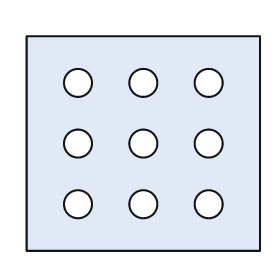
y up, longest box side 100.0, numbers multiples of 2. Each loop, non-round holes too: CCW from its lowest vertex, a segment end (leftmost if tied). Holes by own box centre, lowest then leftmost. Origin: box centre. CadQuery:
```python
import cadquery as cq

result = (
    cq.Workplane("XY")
    .moveTo(-50.0, -46.0)
    .lineTo(50.0, -46.0)
    .lineTo(50.0, 46.0)
    .lineTo(-50.0, 46.0)
    .close()
    .moveTo(-28.0, -26.0)
    .circle(6.0)
    .moveTo(0.0, -26.0)
    .circle(6.0)
    .moveTo(28.0, -26.0)
    .circle(6.0)
    .moveTo(-28.0, 0.0)
    .circle(6.0)
    .moveTo(0.0, 0.0)
    .circle(6.0)
    .moveTo(28.0, 0.0)
    .circle(6.0)
    .moveTo(-28.0, 26.0)
    .circle(6.0)
    .moveTo(0.0, 26.0)
    .circle(6.0)
    .moveTo(28.0, 26.0)
    .circle(6.0)
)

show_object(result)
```